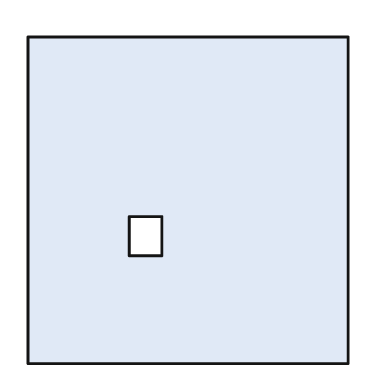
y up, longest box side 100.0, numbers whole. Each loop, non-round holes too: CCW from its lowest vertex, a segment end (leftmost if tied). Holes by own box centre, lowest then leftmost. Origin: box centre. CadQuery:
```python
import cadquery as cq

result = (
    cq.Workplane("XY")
    .moveTo(-49.0, -50.0)
    .lineTo(49.0, -50.0)
    .lineTo(49.0, 50.0)
    .lineTo(-49.0, 50.0)
    .close()
    .moveTo(-18.0, -17.0)
    .lineTo(-8.0, -17.0)
    .lineTo(-8.0, -5.0)
    .lineTo(-18.0, -5.0)
    .close()
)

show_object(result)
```